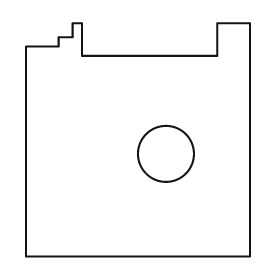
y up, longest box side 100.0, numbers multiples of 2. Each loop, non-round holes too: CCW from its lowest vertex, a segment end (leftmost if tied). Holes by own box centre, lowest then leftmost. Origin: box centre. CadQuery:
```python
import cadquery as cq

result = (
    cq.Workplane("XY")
    .moveTo(-48.0, -50.0)
    .lineTo(48.0, -50.0)
    .lineTo(48.0, 50.0)
    .lineTo(34.0, 50.0)
    .lineTo(34.0, 36.0)
    .lineTo(-24.0, 36.0)
    .lineTo(-24.0, 50.0)
    .lineTo(-28.0, 50.0)
    .lineTo(-28.0, 44.0)
    .lineTo(-34.0, 44.0)
    .lineTo(-34.0, 40.0)
    .lineTo(-48.0, 40.0)
    .close()
    .moveTo(12.0, -6.0)
    .circle(12.0)
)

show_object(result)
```